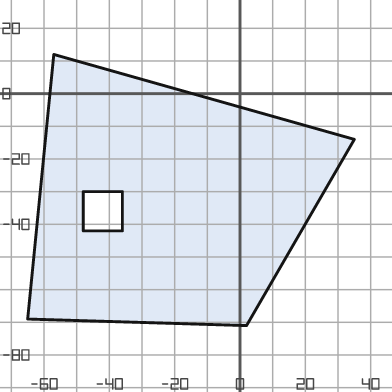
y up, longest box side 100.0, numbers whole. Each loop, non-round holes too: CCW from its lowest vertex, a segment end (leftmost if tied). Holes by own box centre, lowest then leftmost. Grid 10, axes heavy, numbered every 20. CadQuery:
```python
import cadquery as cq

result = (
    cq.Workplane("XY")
    .moveTo(2.0, -71.0)
    .lineTo(35.0, -14.0)
    .lineTo(-57.0, 12.0)
    .lineTo(-65.0, -69.0)
    .close()
    .moveTo(-48.0, -42.0)
    .lineTo(-36.0, -42.0)
    .lineTo(-36.0, -30.0)
    .lineTo(-48.0, -30.0)
    .close()
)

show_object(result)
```